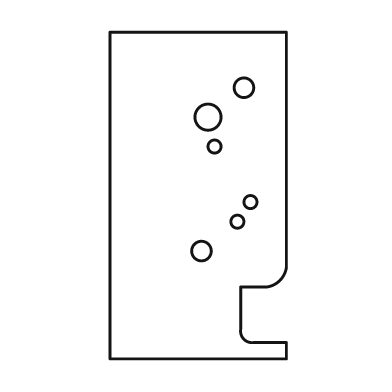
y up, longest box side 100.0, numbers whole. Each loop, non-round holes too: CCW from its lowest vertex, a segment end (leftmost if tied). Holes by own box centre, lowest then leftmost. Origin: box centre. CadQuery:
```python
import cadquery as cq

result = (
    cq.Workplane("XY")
    .moveTo(-27.0, -50.0)
    .lineTo(27.0, -50.0)
    .lineTo(27.0, -45.0)
    .lineTo(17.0, -45.0)
    .threePointArc((14.0, -44.0), (13.0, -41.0))
    .lineTo(13.0, -28.0)
    .lineTo(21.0, -28.0)
    .threePointArc((25.0, -26.0), (27.0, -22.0))
    .lineTo(27.0, 50.0)
    .lineTo(-27.0, 50.0)
    .close()
    .moveTo(1.0, -17.0)
    .circle(3.0)
    .moveTo(12.0, -8.0)
    .circle(2.0)
    .moveTo(16.0, -2.0)
    .circle(2.0)
    .moveTo(5.0, 15.0)
    .circle(2.0)
    .moveTo(3.0, 24.0)
    .circle(4.0)
    .moveTo(14.0, 33.0)
    .circle(3.0)
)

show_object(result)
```